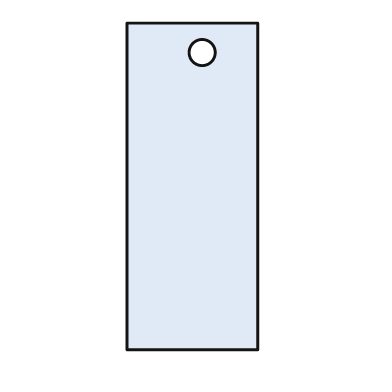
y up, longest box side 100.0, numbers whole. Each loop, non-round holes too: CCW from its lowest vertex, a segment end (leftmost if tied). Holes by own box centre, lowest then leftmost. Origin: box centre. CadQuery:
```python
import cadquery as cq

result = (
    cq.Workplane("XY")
    .moveTo(-20.0, -50.0)
    .lineTo(20.0, -50.0)
    .lineTo(20.0, 50.0)
    .lineTo(-20.0, 50.0)
    .close()
    .moveTo(3.0, 41.0)
    .circle(4.0)
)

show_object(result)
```